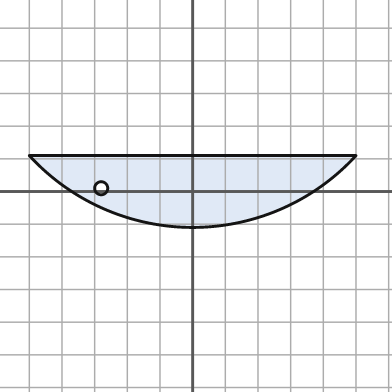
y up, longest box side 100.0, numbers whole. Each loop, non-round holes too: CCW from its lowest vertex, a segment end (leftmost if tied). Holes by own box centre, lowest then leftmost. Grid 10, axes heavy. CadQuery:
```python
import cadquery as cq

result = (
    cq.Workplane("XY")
    .moveTo(-50.0, 11.0)
    .threePointArc((0.0, -11.0), (50.0, 11.0))
    .close()
    .moveTo(-28.0, 1.0)
    .circle(2.0)
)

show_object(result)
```